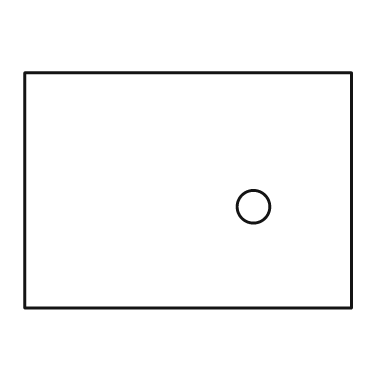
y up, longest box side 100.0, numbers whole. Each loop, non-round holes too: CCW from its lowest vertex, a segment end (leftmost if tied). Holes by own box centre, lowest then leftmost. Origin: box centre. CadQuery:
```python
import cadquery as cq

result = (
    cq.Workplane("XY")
    .moveTo(-50.0, -36.0)
    .lineTo(50.0, -36.0)
    .lineTo(50.0, 36.0)
    .lineTo(-50.0, 36.0)
    .close()
    .moveTo(20.0, -5.0)
    .circle(5.0)
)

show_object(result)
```